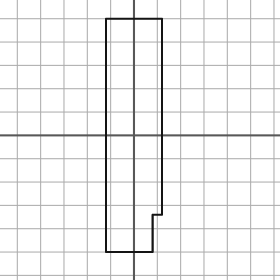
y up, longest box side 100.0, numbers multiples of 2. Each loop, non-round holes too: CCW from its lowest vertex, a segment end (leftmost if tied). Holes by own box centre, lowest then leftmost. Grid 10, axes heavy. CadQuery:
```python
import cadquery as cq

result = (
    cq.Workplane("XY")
    .moveTo(-12.0, -50.0)
    .lineTo(8.0, -50.0)
    .lineTo(8.0, -34.0)
    .lineTo(12.0, -34.0)
    .lineTo(12.0, 50.0)
    .lineTo(-12.0, 50.0)
    .close()
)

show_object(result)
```